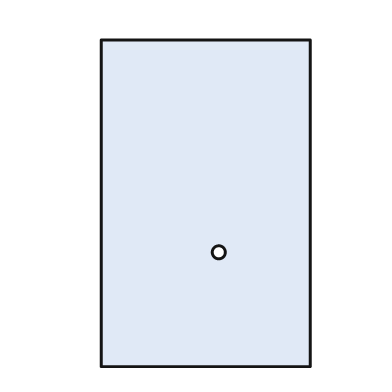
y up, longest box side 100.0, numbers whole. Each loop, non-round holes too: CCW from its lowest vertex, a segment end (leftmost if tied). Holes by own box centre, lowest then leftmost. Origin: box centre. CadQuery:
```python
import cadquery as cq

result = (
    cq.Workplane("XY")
    .moveTo(-32.0, -50.0)
    .lineTo(32.0, -50.0)
    .lineTo(32.0, 50.0)
    .lineTo(-32.0, 50.0)
    .close()
    .moveTo(4.0, -15.0)
    .circle(2.0)
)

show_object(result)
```